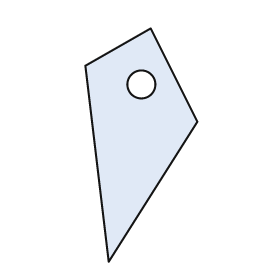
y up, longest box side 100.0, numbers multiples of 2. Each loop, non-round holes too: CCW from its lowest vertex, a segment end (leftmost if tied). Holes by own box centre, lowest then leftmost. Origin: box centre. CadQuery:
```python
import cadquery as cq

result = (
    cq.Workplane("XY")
    .moveTo(-14.0, -50.0)
    .lineTo(24.0, 10.0)
    .lineTo(4.0, 50.0)
    .lineTo(-24.0, 34.0)
    .close()
    .moveTo(0.0, 26.0)
    .circle(6.0)
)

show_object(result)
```